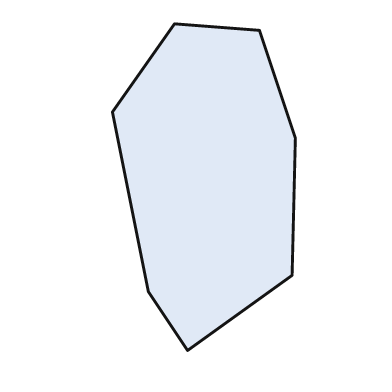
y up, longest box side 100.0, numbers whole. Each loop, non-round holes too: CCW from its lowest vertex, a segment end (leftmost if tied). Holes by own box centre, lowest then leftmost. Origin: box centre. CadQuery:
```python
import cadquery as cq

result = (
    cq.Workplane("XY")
    .moveTo(-5.0, -50.0)
    .lineTo(27.0, -27.0)
    .lineTo(28.0, 15.0)
    .lineTo(17.0, 48.0)
    .lineTo(-9.0, 50.0)
    .lineTo(-28.0, 23.0)
    .lineTo(-17.0, -32.0)
    .close()
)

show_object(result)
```